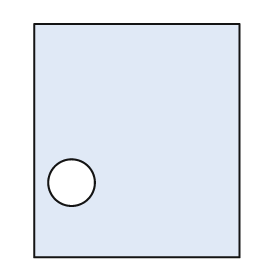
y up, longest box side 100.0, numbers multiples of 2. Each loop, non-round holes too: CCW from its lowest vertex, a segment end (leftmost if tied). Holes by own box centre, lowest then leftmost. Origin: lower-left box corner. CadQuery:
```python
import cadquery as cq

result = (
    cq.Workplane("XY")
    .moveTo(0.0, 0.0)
    .lineTo(88.0, 0.0)
    .lineTo(88.0, 100.0)
    .lineTo(0.0, 100.0)
    .close()
    .moveTo(16.0, 32.0)
    .circle(10.0)
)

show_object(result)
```